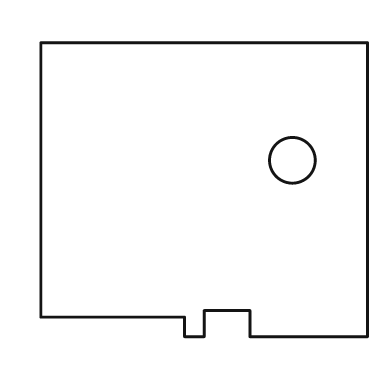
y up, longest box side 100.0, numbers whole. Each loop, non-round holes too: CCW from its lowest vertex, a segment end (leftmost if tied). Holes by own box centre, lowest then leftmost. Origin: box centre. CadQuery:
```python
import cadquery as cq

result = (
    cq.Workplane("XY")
    .moveTo(-6.0, -45.0)
    .lineTo(0.0, -45.0)
    .lineTo(0.0, -37.0)
    .lineTo(14.0, -37.0)
    .lineTo(14.0, -45.0)
    .lineTo(50.0, -45.0)
    .lineTo(50.0, 45.0)
    .lineTo(-50.0, 45.0)
    .lineTo(-50.0, -39.0)
    .lineTo(-6.0, -39.0)
    .close()
    .moveTo(27.0, 9.0)
    .circle(7.0)
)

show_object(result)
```